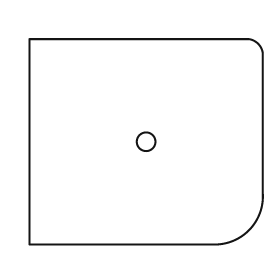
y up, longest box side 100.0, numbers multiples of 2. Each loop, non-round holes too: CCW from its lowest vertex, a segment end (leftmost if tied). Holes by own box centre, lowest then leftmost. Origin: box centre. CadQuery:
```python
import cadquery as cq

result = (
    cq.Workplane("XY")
    .moveTo(-50.0, -44.0)
    .lineTo(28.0, -44.0)
    .threePointArc((44.0, -38.0), (50.0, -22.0))
    .lineTo(50.0, 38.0)
    .threePointArc((48.0, 42.0), (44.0, 44.0))
    .lineTo(-50.0, 44.0)
    .close()
    .moveTo(0.0, 0.0)
    .circle(4.0)
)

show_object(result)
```